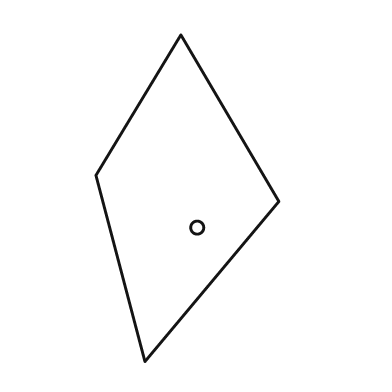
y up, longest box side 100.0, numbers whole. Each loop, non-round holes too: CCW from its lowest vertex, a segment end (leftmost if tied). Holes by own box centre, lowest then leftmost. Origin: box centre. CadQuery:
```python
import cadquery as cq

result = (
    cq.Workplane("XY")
    .moveTo(-13.0, -50.0)
    .lineTo(28.0, -1.0)
    .lineTo(-2.0, 50.0)
    .lineTo(-28.0, 7.0)
    .close()
    .moveTo(3.0, -9.0)
    .circle(2.0)
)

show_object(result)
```